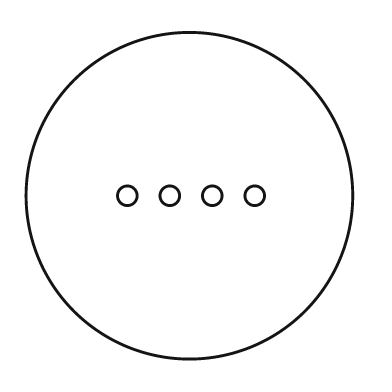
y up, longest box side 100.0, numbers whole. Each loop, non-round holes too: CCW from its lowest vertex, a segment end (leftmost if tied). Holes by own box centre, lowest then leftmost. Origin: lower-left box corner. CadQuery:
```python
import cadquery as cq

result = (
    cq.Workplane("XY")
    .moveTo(50.0, 50.0)
    .circle(50.0)
    .moveTo(31.0, 50.0)
    .circle(3.0)
    .moveTo(44.0, 50.0)
    .circle(3.0)
    .moveTo(57.0, 50.0)
    .circle(3.0)
    .moveTo(70.0, 50.0)
    .circle(3.0)
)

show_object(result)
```